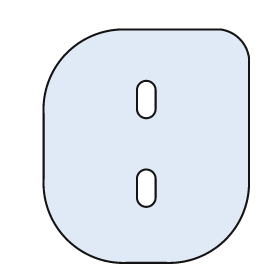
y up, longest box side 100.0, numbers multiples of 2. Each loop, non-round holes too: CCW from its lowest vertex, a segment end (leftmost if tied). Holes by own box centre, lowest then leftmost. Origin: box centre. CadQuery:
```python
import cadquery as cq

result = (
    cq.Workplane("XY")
    .moveTo(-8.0, -50.0)
    .lineTo(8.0, -50.0)
    .threePointArc((34.0, -40.0), (44.0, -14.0))
    .lineTo(44.0, 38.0)
    .threePointArc((40.0, 46.0), (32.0, 50.0))
    .lineTo(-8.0, 50.0)
    .threePointArc((-34.0, 40.0), (-44.0, 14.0))
    .lineTo(-44.0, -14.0)
    .threePointArc((-34.0, -40.0), (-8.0, -50.0))
    .close()
    .moveTo(-4.0, -22.0)
    .threePointArc((0.0, -26.0), (4.0, -22.0))
    .lineTo(4.0, -14.0)
    .threePointArc((0.0, -10.0), (-4.0, -14.0))
    .close()
    .moveTo(-4.0, 16.0)
    .threePointArc((0.0, 12.0), (4.0, 16.0))
    .lineTo(4.0, 24.0)
    .threePointArc((0.0, 28.0), (-4.0, 24.0))
    .close()
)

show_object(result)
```